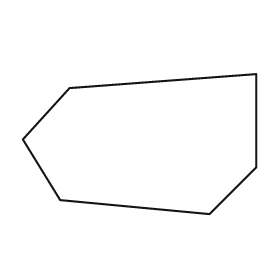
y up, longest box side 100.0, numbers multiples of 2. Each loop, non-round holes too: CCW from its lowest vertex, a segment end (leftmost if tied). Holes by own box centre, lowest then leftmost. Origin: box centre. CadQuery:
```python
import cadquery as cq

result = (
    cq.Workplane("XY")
    .moveTo(30.0, -30.0)
    .lineTo(50.0, -10.0)
    .lineTo(50.0, 30.0)
    .lineTo(-30.0, 24.0)
    .lineTo(-50.0, 2.0)
    .lineTo(-34.0, -24.0)
    .close()
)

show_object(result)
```